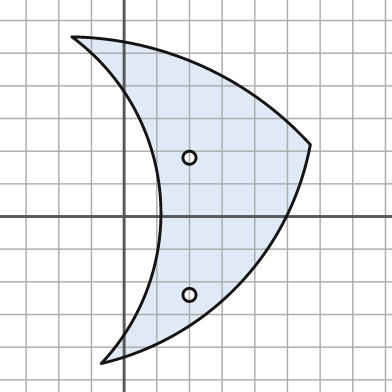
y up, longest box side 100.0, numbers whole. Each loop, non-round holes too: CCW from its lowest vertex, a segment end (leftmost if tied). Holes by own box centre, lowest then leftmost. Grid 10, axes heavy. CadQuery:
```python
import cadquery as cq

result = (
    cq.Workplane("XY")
    .moveTo(-7.0, -45.0)
    .threePointArc((35.0, -21.0), (57.0, 22.0))
    .threePointArc((24.0, 46.0), (-16.0, 55.0))
    .threePointArc((11.0, 7.0), (-7.0, -45.0))
    .close()
    .moveTo(20.0, -24.0)
    .circle(2.0)
    .moveTo(20.0, 18.0)
    .circle(2.0)
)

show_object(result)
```